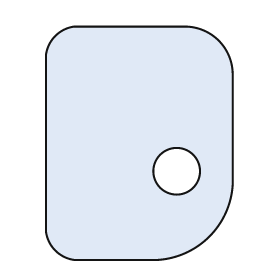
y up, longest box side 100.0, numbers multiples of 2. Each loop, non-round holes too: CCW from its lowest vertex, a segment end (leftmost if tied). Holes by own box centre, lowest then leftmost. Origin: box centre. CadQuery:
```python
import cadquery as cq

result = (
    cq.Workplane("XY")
    .moveTo(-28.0, -50.0)
    .lineTo(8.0, -50.0)
    .threePointArc((30.0, -40.0), (40.0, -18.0))
    .lineTo(40.0, 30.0)
    .threePointArc((34.0, 44.0), (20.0, 50.0))
    .lineTo(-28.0, 50.0)
    .threePointArc((-36.0, 46.0), (-40.0, 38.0))
    .lineTo(-40.0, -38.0)
    .threePointArc((-36.0, -46.0), (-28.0, -50.0))
    .close()
    .moveTo(16.0, -12.0)
    .circle(10.0)
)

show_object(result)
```